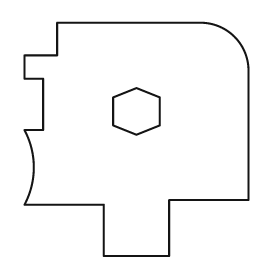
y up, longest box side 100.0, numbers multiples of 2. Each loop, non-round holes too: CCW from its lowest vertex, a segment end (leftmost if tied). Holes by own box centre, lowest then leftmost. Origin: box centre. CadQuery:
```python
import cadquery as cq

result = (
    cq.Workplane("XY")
    .moveTo(-14.0, -50.0)
    .lineTo(14.0, -50.0)
    .lineTo(14.0, -26.0)
    .lineTo(48.0, -26.0)
    .lineTo(48.0, 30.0)
    .threePointArc((42.0, 44.0), (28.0, 50.0))
    .lineTo(-34.0, 50.0)
    .lineTo(-34.0, 36.0)
    .lineTo(-48.0, 36.0)
    .lineTo(-48.0, 26.0)
    .lineTo(-40.0, 26.0)
    .lineTo(-40.0, 4.0)
    .lineTo(-48.0, 4.0)
    .threePointArc((-44.0, -12.0), (-48.0, -28.0))
    .lineTo(-14.0, -28.0)
    .close()
    .moveTo(0.0, 2.0)
    .lineTo(10.0, 6.0)
    .lineTo(10.0, 18.0)
    .lineTo(0.0, 22.0)
    .lineTo(-10.0, 18.0)
    .lineTo(-10.0, 6.0)
    .close()
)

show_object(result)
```